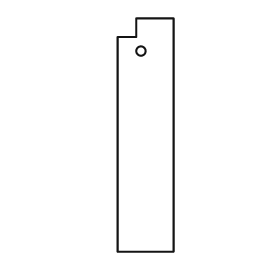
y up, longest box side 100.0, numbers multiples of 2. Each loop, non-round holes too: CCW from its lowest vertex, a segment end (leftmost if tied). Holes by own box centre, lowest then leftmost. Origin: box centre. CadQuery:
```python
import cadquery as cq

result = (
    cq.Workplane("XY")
    .moveTo(-12.0, -50.0)
    .lineTo(12.0, -50.0)
    .lineTo(12.0, 50.0)
    .lineTo(-4.0, 50.0)
    .lineTo(-4.0, 42.0)
    .lineTo(-12.0, 42.0)
    .close()
    .moveTo(-2.0, 36.0)
    .circle(2.0)
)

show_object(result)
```